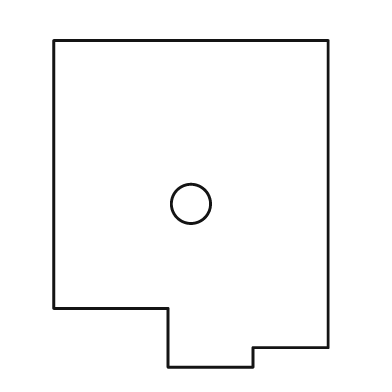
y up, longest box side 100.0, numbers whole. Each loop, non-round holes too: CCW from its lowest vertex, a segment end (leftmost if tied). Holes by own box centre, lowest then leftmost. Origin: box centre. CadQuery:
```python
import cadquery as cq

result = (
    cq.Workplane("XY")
    .moveTo(-7.0, -50.0)
    .lineTo(19.0, -50.0)
    .lineTo(19.0, -44.0)
    .lineTo(42.0, -44.0)
    .lineTo(42.0, 50.0)
    .lineTo(-42.0, 50.0)
    .lineTo(-42.0, -32.0)
    .lineTo(-7.0, -32.0)
    .close()
    .moveTo(0.0, 0.0)
    .circle(6.0)
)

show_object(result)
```